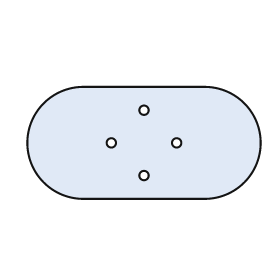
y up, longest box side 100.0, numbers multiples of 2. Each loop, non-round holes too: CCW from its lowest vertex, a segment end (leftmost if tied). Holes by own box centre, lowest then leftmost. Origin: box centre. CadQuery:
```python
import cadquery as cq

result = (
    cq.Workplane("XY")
    .moveTo(-26.0, -24.0)
    .lineTo(26.0, -24.0)
    .threePointArc((50.0, 0.0), (26.0, 24.0))
    .lineTo(-26.0, 24.0)
    .threePointArc((-50.0, 0.0), (-26.0, -24.0))
    .close()
    .moveTo(0.0, -14.0)
    .circle(2.0)
    .moveTo(-14.0, 0.0)
    .circle(2.0)
    .moveTo(14.0, 0.0)
    .circle(2.0)
    .moveTo(0.0, 14.0)
    .circle(2.0)
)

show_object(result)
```